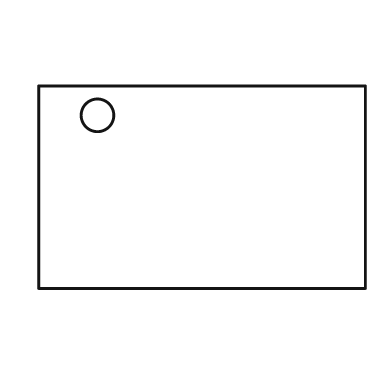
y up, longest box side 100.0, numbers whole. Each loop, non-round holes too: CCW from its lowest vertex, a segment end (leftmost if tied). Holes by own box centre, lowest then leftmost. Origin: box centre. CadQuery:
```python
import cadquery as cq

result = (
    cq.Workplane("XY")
    .moveTo(-50.0, -31.0)
    .lineTo(50.0, -31.0)
    .lineTo(50.0, 31.0)
    .lineTo(-50.0, 31.0)
    .close()
    .moveTo(-32.0, 22.0)
    .circle(5.0)
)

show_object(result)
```